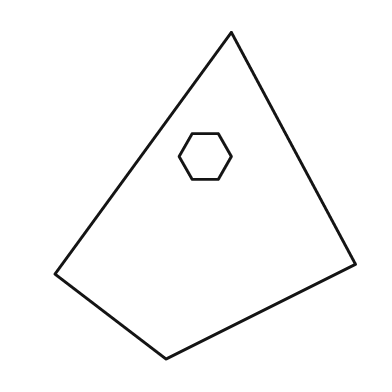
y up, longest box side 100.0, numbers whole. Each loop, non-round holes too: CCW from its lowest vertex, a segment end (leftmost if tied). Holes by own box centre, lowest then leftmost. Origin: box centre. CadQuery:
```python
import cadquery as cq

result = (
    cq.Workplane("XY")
    .moveTo(-12.0, -50.0)
    .lineTo(46.0, -21.0)
    .lineTo(8.0, 50.0)
    .lineTo(-46.0, -24.0)
    .close()
    .moveTo(-4.0, 5.0)
    .lineTo(4.0, 5.0)
    .lineTo(8.0, 12.0)
    .lineTo(4.0, 19.0)
    .lineTo(-4.0, 19.0)
    .lineTo(-8.0, 12.0)
    .close()
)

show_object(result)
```